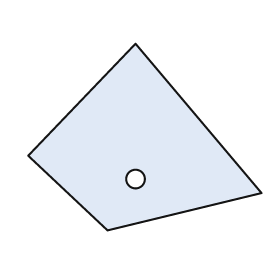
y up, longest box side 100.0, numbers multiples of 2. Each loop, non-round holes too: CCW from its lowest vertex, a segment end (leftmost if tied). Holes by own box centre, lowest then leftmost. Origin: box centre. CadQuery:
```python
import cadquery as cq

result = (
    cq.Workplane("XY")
    .moveTo(-16.0, -40.0)
    .lineTo(50.0, -24.0)
    .lineTo(-4.0, 40.0)
    .lineTo(-50.0, -8.0)
    .close()
    .moveTo(-4.0, -18.0)
    .circle(4.0)
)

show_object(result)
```